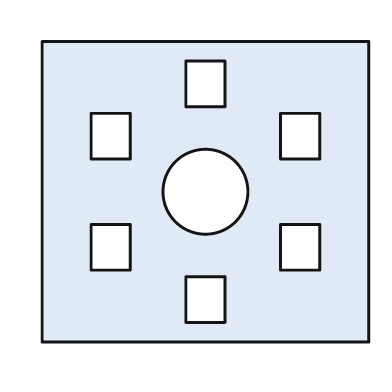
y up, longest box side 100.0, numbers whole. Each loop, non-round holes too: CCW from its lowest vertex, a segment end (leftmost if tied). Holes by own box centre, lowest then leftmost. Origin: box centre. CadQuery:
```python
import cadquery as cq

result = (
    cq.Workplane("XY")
    .moveTo(-50.0, -46.0)
    .lineTo(50.0, -46.0)
    .lineTo(50.0, 46.0)
    .lineTo(-50.0, 46.0)
    .close()
    .moveTo(-6.0, -40.0)
    .lineTo(6.0, -40.0)
    .lineTo(6.0, -26.0)
    .lineTo(-6.0, -26.0)
    .close()
    .moveTo(-35.0, -24.0)
    .lineTo(-23.0, -24.0)
    .lineTo(-23.0, -10.0)
    .lineTo(-35.0, -10.0)
    .close()
    .moveTo(23.0, -24.0)
    .lineTo(35.0, -24.0)
    .lineTo(35.0, -10.0)
    .lineTo(23.0, -10.0)
    .close()
    .moveTo(0.0, 0.0)
    .circle(13.0)
    .moveTo(-35.0, 10.0)
    .lineTo(-23.0, 10.0)
    .lineTo(-23.0, 24.0)
    .lineTo(-35.0, 24.0)
    .close()
    .moveTo(23.0, 10.0)
    .lineTo(35.0, 10.0)
    .lineTo(35.0, 24.0)
    .lineTo(23.0, 24.0)
    .close()
    .moveTo(-6.0, 26.0)
    .lineTo(6.0, 26.0)
    .lineTo(6.0, 40.0)
    .lineTo(-6.0, 40.0)
    .close()
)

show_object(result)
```